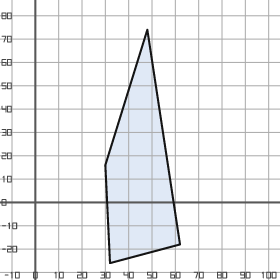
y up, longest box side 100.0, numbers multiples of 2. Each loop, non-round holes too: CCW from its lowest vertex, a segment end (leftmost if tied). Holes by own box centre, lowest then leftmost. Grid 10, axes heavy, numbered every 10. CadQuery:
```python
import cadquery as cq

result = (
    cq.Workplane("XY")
    .moveTo(32.0, -26.0)
    .lineTo(62.0, -18.0)
    .lineTo(48.0, 74.0)
    .lineTo(30.0, 16.0)
    .close()
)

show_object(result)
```